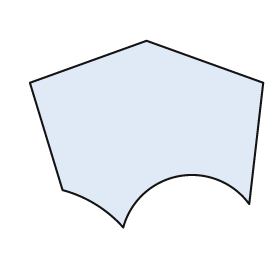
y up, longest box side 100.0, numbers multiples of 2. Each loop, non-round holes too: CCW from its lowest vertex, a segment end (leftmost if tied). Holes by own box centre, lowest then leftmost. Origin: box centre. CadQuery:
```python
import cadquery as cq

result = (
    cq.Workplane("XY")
    .moveTo(-10.0, -40.0)
    .threePointArc((14.0, -18.0), (44.0, -30.0))
    .lineTo(50.0, 22.0)
    .lineTo(0.0, 40.0)
    .lineTo(-50.0, 22.0)
    .lineTo(-36.0, -24.0)
    .threePointArc((-22.0, -30.0), (-10.0, -40.0))
    .close()
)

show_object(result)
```